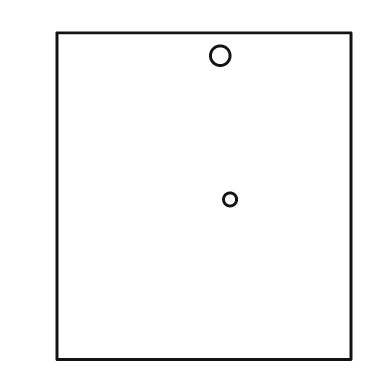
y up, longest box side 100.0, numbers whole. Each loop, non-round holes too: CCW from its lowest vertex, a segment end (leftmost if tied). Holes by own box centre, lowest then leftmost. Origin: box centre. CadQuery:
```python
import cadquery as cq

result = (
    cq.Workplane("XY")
    .moveTo(-45.0, -50.0)
    .lineTo(45.0, -50.0)
    .lineTo(45.0, 50.0)
    .lineTo(-45.0, 50.0)
    .close()
    .moveTo(8.0, -1.0)
    .circle(2.0)
    .moveTo(5.0, 43.0)
    .circle(3.0)
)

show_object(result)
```